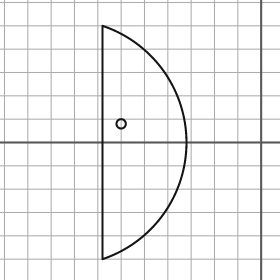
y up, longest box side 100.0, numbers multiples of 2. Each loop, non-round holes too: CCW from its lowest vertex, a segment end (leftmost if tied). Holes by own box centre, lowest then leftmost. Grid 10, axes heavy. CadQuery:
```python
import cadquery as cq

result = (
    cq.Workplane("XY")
    .moveTo(-68.0, -50.0)
    .threePointArc((-32.0, 0.0), (-68.0, 50.0))
    .close()
    .moveTo(-60.0, 8.0)
    .circle(2.0)
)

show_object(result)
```